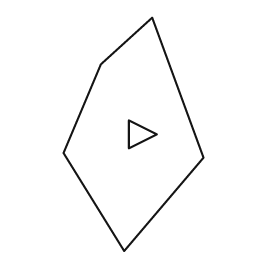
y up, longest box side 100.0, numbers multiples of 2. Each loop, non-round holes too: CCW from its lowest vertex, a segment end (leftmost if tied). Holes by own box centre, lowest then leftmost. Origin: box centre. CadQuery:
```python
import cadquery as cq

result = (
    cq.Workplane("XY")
    .moveTo(-4.0, -50.0)
    .lineTo(30.0, -10.0)
    .lineTo(8.0, 50.0)
    .lineTo(-14.0, 30.0)
    .lineTo(-30.0, -8.0)
    .close()
    .moveTo(-2.0, -6.0)
    .lineTo(10.0, 0.0)
    .lineTo(-2.0, 6.0)
    .close()
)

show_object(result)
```